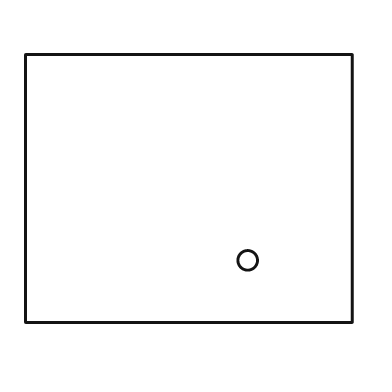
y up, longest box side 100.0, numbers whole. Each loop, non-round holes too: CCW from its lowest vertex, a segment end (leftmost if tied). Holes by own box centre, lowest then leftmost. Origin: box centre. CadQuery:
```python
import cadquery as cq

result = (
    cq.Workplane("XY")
    .moveTo(-50.0, -41.0)
    .lineTo(50.0, -41.0)
    .lineTo(50.0, 41.0)
    .lineTo(-50.0, 41.0)
    .close()
    .moveTo(18.0, -22.0)
    .circle(3.0)
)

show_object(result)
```